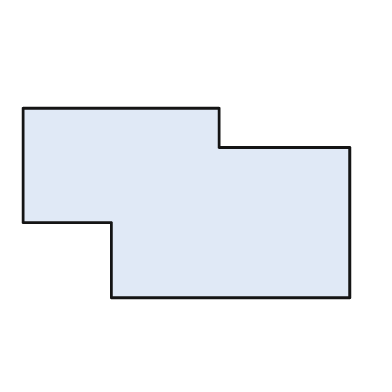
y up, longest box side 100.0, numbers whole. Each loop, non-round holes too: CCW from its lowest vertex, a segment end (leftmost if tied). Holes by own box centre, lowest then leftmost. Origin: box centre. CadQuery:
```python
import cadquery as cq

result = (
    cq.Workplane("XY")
    .moveTo(-23.0, -29.0)
    .lineTo(50.0, -29.0)
    .lineTo(50.0, 17.0)
    .lineTo(10.0, 17.0)
    .lineTo(10.0, 29.0)
    .lineTo(-50.0, 29.0)
    .lineTo(-50.0, -6.0)
    .lineTo(-23.0, -6.0)
    .close()
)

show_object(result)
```